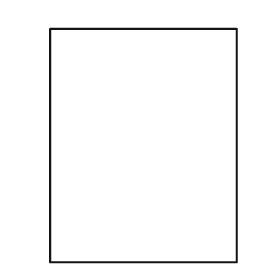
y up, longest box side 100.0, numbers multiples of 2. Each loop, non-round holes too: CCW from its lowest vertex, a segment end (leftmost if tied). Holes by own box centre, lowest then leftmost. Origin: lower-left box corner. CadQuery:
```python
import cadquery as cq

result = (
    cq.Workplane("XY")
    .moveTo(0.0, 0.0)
    .lineTo(80.0, 0.0)
    .lineTo(80.0, 100.0)
    .lineTo(0.0, 100.0)
    .close()
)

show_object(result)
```